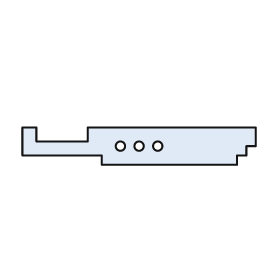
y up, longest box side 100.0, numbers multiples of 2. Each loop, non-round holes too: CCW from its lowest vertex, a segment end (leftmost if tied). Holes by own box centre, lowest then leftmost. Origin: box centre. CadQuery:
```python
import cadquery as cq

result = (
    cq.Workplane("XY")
    .moveTo(-16.0, -8.0)
    .lineTo(42.0, -8.0)
    .lineTo(42.0, -4.0)
    .lineTo(46.0, -4.0)
    .lineTo(46.0, 0.0)
    .lineTo(50.0, 0.0)
    .lineTo(50.0, 8.0)
    .lineTo(-22.0, 8.0)
    .lineTo(-22.0, 2.0)
    .lineTo(-44.0, 2.0)
    .lineTo(-44.0, 8.0)
    .lineTo(-50.0, 8.0)
    .lineTo(-50.0, -4.0)
    .lineTo(-16.0, -4.0)
    .close()
    .moveTo(-8.0, 0.0)
    .circle(2.0)
    .moveTo(0.0, 0.0)
    .circle(2.0)
    .moveTo(8.0, 0.0)
    .circle(2.0)
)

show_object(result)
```